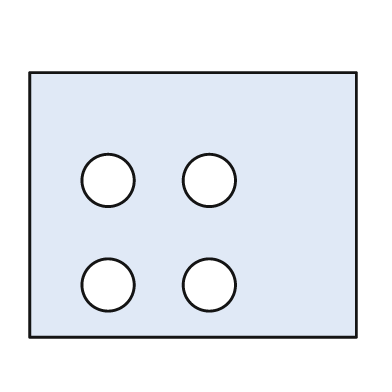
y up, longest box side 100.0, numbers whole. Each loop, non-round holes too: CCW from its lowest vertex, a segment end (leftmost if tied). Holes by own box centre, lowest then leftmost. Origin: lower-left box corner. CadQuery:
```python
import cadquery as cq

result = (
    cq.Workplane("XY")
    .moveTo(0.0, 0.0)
    .lineTo(100.0, 0.0)
    .lineTo(100.0, 81.0)
    .lineTo(0.0, 81.0)
    .close()
    .moveTo(24.0, 16.0)
    .circle(8.0)
    .moveTo(55.0, 16.0)
    .circle(8.0)
    .moveTo(24.0, 48.0)
    .circle(8.0)
    .moveTo(55.0, 48.0)
    .circle(8.0)
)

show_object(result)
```